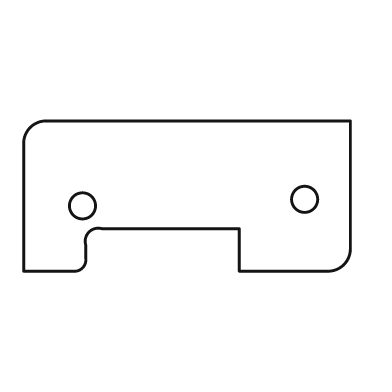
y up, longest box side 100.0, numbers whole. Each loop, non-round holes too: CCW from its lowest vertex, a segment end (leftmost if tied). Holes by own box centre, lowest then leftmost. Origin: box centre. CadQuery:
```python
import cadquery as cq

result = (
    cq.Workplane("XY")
    .moveTo(-50.0, -23.0)
    .lineTo(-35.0, -23.0)
    .threePointArc((-32.0, -22.0), (-31.0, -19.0))
    .lineTo(-31.0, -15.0)
    .threePointArc((-30.0, -11.0), (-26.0, -10.0))
    .lineTo(16.0, -10.0)
    .lineTo(16.0, -23.0)
    .lineTo(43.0, -23.0)
    .threePointArc((48.0, -21.0), (50.0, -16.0))
    .lineTo(50.0, 23.0)
    .lineTo(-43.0, 23.0)
    .threePointArc((-48.0, 21.0), (-50.0, 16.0))
    .close()
    .moveTo(-32.0, -3.0)
    .circle(4.0)
    .moveTo(36.0, -1.0)
    .circle(4.0)
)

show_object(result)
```